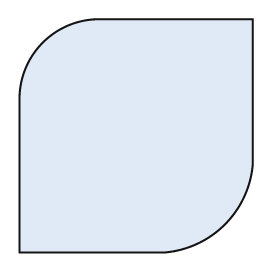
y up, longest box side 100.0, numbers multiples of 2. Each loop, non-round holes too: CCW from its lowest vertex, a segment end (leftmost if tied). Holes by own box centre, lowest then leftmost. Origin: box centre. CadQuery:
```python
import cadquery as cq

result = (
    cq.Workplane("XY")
    .moveTo(-50.0, -50.0)
    .lineTo(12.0, -50.0)
    .threePointArc((38.0, -38.0), (50.0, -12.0))
    .lineTo(50.0, 50.0)
    .lineTo(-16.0, 50.0)
    .threePointArc((-40.0, 40.0), (-50.0, 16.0))
    .close()
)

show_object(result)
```